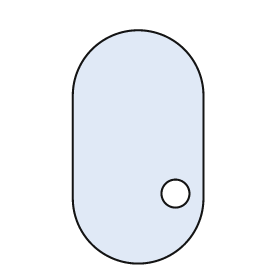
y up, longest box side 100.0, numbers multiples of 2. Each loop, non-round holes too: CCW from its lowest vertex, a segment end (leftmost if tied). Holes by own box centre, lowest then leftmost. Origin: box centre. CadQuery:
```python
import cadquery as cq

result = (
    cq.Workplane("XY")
    .moveTo(-28.0, -22.0)
    .threePointArc((0.0, -50.0), (28.0, -22.0))
    .lineTo(28.0, 22.0)
    .threePointArc((0.0, 50.0), (-28.0, 22.0))
    .close()
    .moveTo(16.0, -20.0)
    .circle(6.0)
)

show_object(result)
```